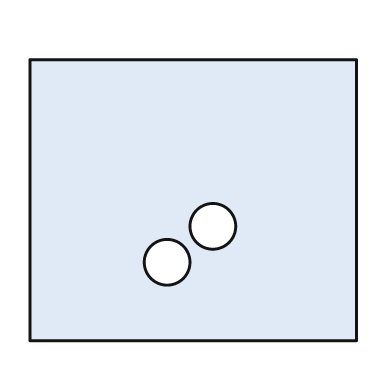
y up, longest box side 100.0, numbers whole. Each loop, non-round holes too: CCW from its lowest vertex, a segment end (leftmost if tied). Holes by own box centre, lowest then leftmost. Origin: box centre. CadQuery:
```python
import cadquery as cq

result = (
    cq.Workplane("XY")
    .moveTo(-50.0, -43.0)
    .lineTo(50.0, -43.0)
    .lineTo(50.0, 43.0)
    .lineTo(-50.0, 43.0)
    .close()
    .moveTo(-8.0, -19.0)
    .circle(7.0)
    .moveTo(6.0, -8.0)
    .circle(7.0)
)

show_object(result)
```